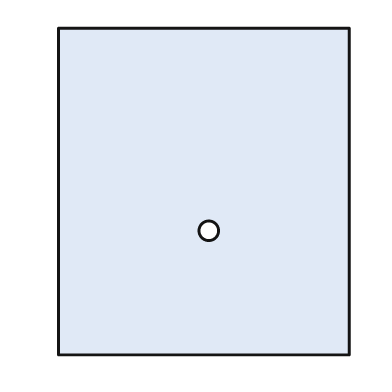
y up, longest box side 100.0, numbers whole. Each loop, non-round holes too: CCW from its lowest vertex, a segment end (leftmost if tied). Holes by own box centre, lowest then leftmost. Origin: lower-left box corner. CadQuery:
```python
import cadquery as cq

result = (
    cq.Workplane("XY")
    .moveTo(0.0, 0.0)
    .lineTo(89.0, 0.0)
    .lineTo(89.0, 100.0)
    .lineTo(0.0, 100.0)
    .close()
    .moveTo(46.0, 38.0)
    .circle(3.0)
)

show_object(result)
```